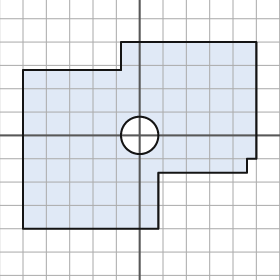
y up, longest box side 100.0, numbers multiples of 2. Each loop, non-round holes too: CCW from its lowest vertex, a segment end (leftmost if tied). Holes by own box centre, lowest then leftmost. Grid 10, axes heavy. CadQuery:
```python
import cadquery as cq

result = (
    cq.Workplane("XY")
    .moveTo(-50.0, -40.0)
    .lineTo(8.0, -40.0)
    .lineTo(8.0, -16.0)
    .lineTo(46.0, -16.0)
    .lineTo(46.0, -10.0)
    .lineTo(50.0, -10.0)
    .lineTo(50.0, 40.0)
    .lineTo(-8.0, 40.0)
    .lineTo(-8.0, 28.0)
    .lineTo(-50.0, 28.0)
    .close()
    .moveTo(0.0, 0.0)
    .circle(8.0)
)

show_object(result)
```